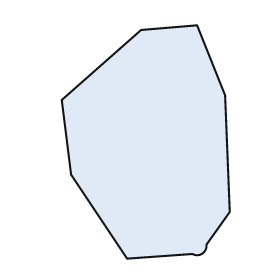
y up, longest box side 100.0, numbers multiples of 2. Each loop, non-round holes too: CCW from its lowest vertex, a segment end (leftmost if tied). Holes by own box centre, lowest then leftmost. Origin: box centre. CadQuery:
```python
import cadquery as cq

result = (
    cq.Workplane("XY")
    .moveTo(-8.0, -50.0)
    .lineTo(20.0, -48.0)
    .threePointArc((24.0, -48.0), (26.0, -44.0))
    .lineTo(36.0, -30.0)
    .lineTo(34.0, 20.0)
    .lineTo(22.0, 50.0)
    .lineTo(-2.0, 48.0)
    .lineTo(-36.0, 18.0)
    .lineTo(-32.0, -14.0)
    .close()
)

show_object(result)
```